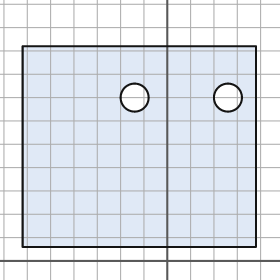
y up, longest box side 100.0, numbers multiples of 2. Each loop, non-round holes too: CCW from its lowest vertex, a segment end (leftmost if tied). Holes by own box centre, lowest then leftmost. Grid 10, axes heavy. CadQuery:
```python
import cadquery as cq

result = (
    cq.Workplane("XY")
    .moveTo(-62.0, 6.0)
    .lineTo(38.0, 6.0)
    .lineTo(38.0, 92.0)
    .lineTo(-62.0, 92.0)
    .close()
    .moveTo(-14.0, 70.0)
    .circle(6.0)
    .moveTo(26.0, 70.0)
    .circle(6.0)
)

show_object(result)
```